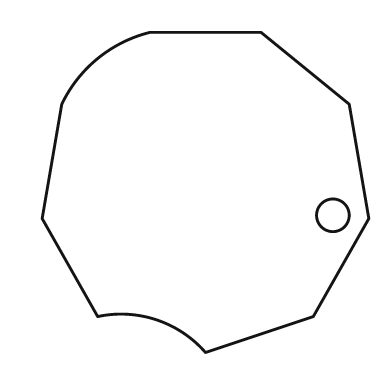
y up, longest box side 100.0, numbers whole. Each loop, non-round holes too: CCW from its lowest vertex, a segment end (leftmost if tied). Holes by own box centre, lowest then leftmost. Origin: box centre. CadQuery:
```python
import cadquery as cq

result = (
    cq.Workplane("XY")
    .moveTo(0.0, -49.0)
    .lineTo(33.0, -38.0)
    .lineTo(50.0, -8.0)
    .lineTo(44.0, 27.0)
    .lineTo(17.0, 49.0)
    .lineTo(-17.0, 49.0)
    .threePointArc((-33.0, 41.0), (-44.0, 27.0))
    .lineTo(-50.0, -8.0)
    .lineTo(-33.0, -38.0)
    .threePointArc((-15.0, -39.0), (0.0, -49.0))
    .close()
    .moveTo(39.0, -7.0)
    .circle(5.0)
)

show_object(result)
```